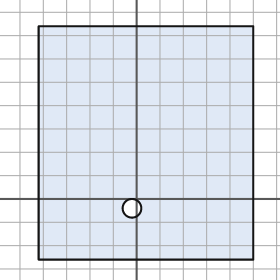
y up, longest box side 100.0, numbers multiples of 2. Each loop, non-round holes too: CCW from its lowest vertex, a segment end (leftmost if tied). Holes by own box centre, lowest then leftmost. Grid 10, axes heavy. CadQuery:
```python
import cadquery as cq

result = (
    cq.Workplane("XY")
    .moveTo(-42.0, -26.0)
    .lineTo(50.0, -26.0)
    .lineTo(50.0, 74.0)
    .lineTo(-42.0, 74.0)
    .close()
    .moveTo(-2.0, -4.0)
    .circle(4.0)
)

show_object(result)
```